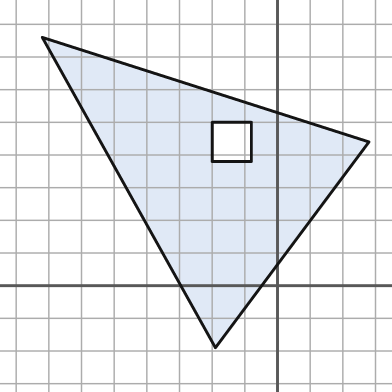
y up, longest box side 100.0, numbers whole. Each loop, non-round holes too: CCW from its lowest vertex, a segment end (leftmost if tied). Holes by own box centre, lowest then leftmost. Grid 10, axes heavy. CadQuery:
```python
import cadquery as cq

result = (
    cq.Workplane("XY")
    .moveTo(-19.0, -19.0)
    .lineTo(28.0, 44.0)
    .lineTo(-72.0, 76.0)
    .close()
    .moveTo(-20.0, 38.0)
    .lineTo(-8.0, 38.0)
    .lineTo(-8.0, 50.0)
    .lineTo(-20.0, 50.0)
    .close()
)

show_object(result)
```